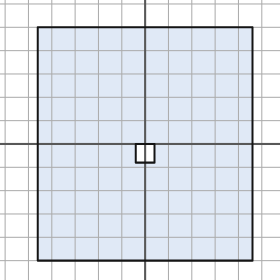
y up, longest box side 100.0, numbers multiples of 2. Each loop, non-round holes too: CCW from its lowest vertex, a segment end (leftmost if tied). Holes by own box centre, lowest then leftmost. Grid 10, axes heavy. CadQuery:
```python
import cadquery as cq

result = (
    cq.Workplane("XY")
    .moveTo(-46.0, -50.0)
    .lineTo(46.0, -50.0)
    .lineTo(46.0, 50.0)
    .lineTo(-46.0, 50.0)
    .close()
    .moveTo(-4.0, -8.0)
    .lineTo(4.0, -8.0)
    .lineTo(4.0, 0.0)
    .lineTo(-4.0, 0.0)
    .close()
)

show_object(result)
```